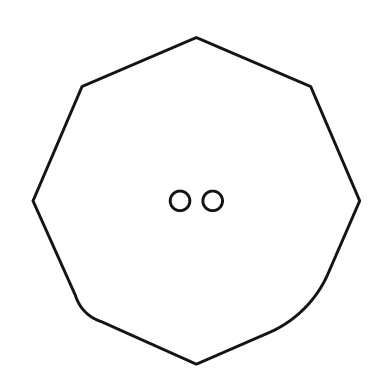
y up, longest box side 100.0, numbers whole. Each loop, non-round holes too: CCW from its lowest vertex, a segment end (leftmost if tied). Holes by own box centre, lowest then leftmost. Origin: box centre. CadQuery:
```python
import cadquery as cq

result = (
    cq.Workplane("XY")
    .moveTo(0.0, -50.0)
    .lineTo(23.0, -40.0)
    .threePointArc((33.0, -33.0), (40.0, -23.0))
    .lineTo(50.0, 0.0)
    .lineTo(35.0, 35.0)
    .lineTo(0.0, 50.0)
    .lineTo(-35.0, 35.0)
    .lineTo(-50.0, 0.0)
    .lineTo(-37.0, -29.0)
    .threePointArc((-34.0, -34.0), (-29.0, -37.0))
    .close()
    .moveTo(-5.0, 0.0)
    .circle(3.0)
    .moveTo(5.0, 0.0)
    .circle(3.0)
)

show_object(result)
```